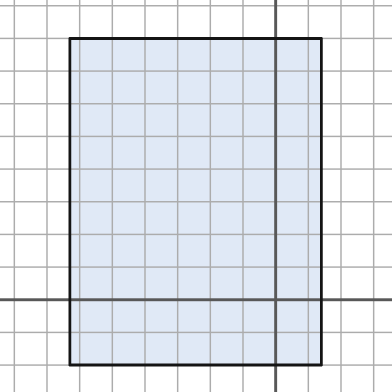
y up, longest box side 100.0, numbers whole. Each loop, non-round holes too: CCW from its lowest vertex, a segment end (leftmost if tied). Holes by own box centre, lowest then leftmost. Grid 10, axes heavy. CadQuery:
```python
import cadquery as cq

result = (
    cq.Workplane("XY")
    .moveTo(-63.0, -20.0)
    .lineTo(14.0, -20.0)
    .lineTo(14.0, 80.0)
    .lineTo(-63.0, 80.0)
    .close()
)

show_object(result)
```